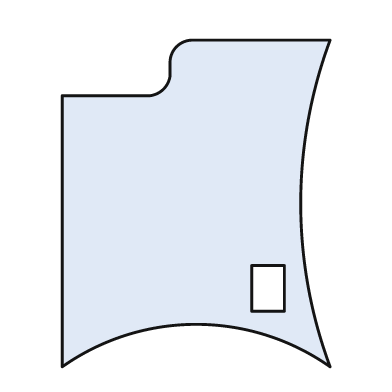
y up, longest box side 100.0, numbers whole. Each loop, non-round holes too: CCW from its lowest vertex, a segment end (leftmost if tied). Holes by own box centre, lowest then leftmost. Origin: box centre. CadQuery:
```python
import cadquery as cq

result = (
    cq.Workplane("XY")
    .moveTo(-41.0, -50.0)
    .threePointArc((0.0, -37.0), (41.0, -50.0))
    .threePointArc((32.0, 0.0), (41.0, 50.0))
    .lineTo(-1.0, 50.0)
    .threePointArc((-6.0, 48.0), (-8.0, 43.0))
    .lineTo(-8.0, 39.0)
    .threePointArc((-10.0, 35.0), (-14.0, 33.0))
    .lineTo(-41.0, 33.0)
    .close()
    .moveTo(17.0, -33.0)
    .lineTo(27.0, -33.0)
    .lineTo(27.0, -19.0)
    .lineTo(17.0, -19.0)
    .close()
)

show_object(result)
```